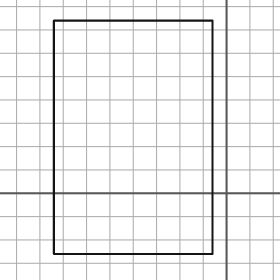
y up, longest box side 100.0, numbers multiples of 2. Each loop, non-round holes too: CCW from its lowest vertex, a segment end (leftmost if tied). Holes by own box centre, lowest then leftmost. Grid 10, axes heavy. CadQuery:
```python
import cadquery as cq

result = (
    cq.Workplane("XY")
    .moveTo(-74.0, -26.0)
    .lineTo(-6.0, -26.0)
    .lineTo(-6.0, 74.0)
    .lineTo(-74.0, 74.0)
    .close()
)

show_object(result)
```